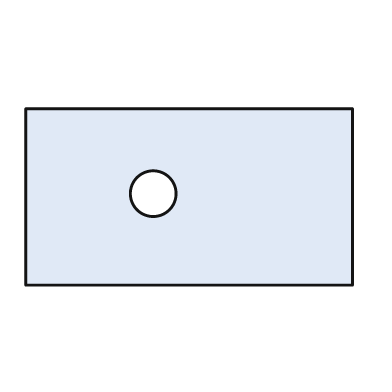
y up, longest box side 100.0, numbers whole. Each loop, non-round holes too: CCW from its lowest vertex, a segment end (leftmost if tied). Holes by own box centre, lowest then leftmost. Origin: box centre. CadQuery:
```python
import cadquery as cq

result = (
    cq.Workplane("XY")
    .moveTo(-50.0, -27.0)
    .lineTo(50.0, -27.0)
    .lineTo(50.0, 27.0)
    .lineTo(-50.0, 27.0)
    .close()
    .moveTo(-11.0, 1.0)
    .circle(7.0)
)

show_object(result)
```